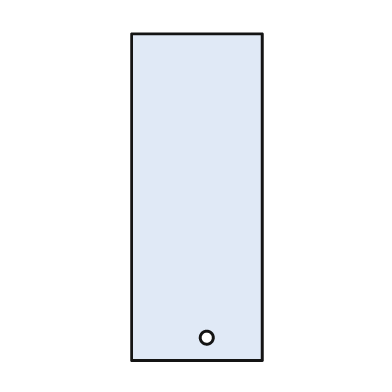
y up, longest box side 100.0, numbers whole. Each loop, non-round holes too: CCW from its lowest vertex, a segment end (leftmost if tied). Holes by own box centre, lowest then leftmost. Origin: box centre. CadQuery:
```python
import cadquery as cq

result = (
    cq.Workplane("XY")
    .moveTo(-20.0, -50.0)
    .lineTo(20.0, -50.0)
    .lineTo(20.0, 50.0)
    .lineTo(-20.0, 50.0)
    .close()
    .moveTo(3.0, -43.0)
    .circle(2.0)
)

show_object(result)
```